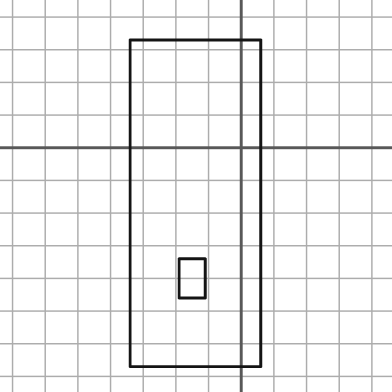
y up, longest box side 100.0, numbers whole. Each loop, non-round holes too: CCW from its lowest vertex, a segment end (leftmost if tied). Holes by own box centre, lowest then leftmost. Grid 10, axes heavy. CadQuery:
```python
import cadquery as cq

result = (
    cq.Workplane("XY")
    .moveTo(-34.0, -67.0)
    .lineTo(6.0, -67.0)
    .lineTo(6.0, 33.0)
    .lineTo(-34.0, 33.0)
    .close()
    .moveTo(-19.0, -46.0)
    .lineTo(-11.0, -46.0)
    .lineTo(-11.0, -34.0)
    .lineTo(-19.0, -34.0)
    .close()
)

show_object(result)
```